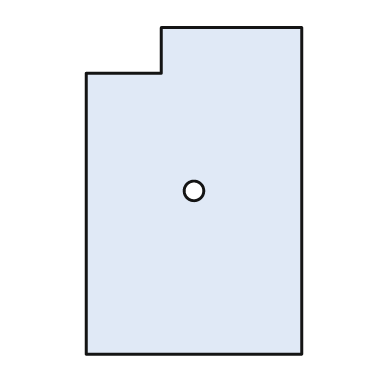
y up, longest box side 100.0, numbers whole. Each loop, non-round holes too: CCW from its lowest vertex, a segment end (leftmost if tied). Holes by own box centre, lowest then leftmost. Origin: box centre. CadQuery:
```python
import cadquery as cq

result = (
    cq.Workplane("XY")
    .moveTo(-33.0, -50.0)
    .lineTo(33.0, -50.0)
    .lineTo(33.0, 50.0)
    .lineTo(-10.0, 50.0)
    .lineTo(-10.0, 36.0)
    .lineTo(-33.0, 36.0)
    .close()
    .moveTo(0.0, 0.0)
    .circle(3.0)
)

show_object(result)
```